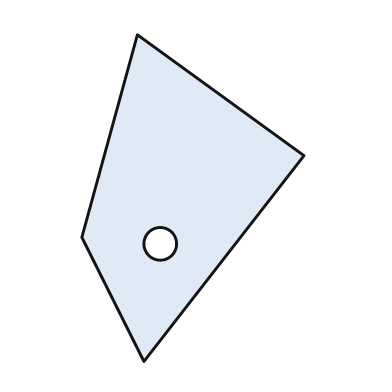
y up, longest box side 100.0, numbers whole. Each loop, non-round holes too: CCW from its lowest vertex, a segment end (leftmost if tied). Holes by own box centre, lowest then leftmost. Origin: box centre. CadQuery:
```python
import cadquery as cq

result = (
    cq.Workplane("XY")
    .moveTo(-15.0, -50.0)
    .lineTo(34.0, 13.0)
    .lineTo(-17.0, 50.0)
    .lineTo(-34.0, -12.0)
    .close()
    .moveTo(-10.0, -14.0)
    .circle(5.0)
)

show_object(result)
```